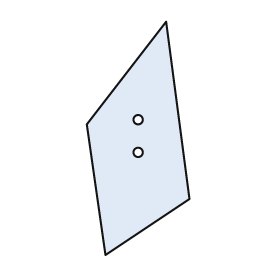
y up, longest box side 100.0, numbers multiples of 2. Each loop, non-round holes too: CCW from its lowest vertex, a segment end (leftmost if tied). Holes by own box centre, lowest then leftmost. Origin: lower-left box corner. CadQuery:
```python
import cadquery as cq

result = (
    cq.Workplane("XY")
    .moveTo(8.0, 0.0)
    .lineTo(44.0, 24.0)
    .lineTo(34.0, 100.0)
    .lineTo(0.0, 56.0)
    .close()
    .moveTo(22.0, 44.0)
    .circle(2.0)
    .moveTo(22.0, 58.0)
    .circle(2.0)
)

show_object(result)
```